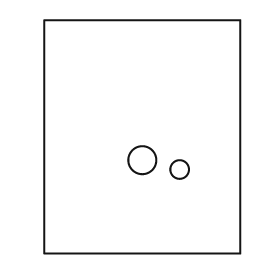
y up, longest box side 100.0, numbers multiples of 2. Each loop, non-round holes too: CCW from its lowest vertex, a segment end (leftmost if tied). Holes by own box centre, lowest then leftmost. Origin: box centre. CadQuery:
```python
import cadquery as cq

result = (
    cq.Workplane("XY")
    .moveTo(-42.0, -50.0)
    .lineTo(42.0, -50.0)
    .lineTo(42.0, 50.0)
    .lineTo(-42.0, 50.0)
    .close()
    .moveTo(16.0, -14.0)
    .circle(4.0)
    .moveTo(0.0, -10.0)
    .circle(6.0)
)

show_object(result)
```